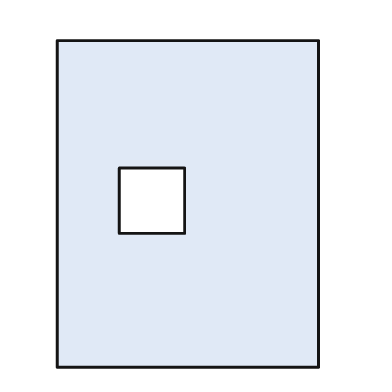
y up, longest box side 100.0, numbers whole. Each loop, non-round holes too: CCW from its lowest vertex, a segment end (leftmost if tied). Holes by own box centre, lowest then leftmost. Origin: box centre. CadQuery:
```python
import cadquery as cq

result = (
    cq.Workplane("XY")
    .moveTo(-40.0, -50.0)
    .lineTo(40.0, -50.0)
    .lineTo(40.0, 50.0)
    .lineTo(-40.0, 50.0)
    .close()
    .moveTo(-21.0, -9.0)
    .lineTo(-1.0, -9.0)
    .lineTo(-1.0, 11.0)
    .lineTo(-21.0, 11.0)
    .close()
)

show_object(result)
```